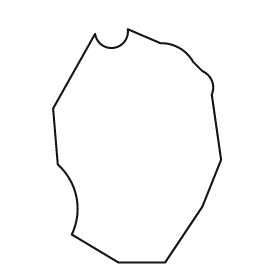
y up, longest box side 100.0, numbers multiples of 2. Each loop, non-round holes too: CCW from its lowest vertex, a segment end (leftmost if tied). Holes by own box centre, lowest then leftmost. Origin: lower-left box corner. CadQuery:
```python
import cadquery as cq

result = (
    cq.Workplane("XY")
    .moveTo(28.0, 0.0)
    .lineTo(48.0, 0.0)
    .lineTo(64.0, 24.0)
    .lineTo(72.0, 44.0)
    .lineTo(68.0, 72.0)
    .threePointArc((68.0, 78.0), (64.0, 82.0))
    .lineTo(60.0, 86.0)
    .threePointArc((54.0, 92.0), (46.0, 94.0))
    .lineTo(32.0, 100.0)
    .threePointArc((26.0, 92.0), (18.0, 98.0))
    .lineTo(0.0, 66.0)
    .lineTo(2.0, 42.0)
    .threePointArc((10.0, 28.0), (8.0, 12.0))
    .close()
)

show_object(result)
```